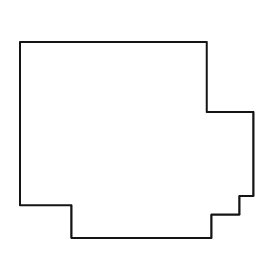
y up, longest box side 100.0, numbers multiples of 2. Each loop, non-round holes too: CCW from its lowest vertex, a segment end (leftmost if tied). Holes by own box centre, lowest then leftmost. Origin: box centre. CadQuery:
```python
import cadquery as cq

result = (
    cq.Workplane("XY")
    .moveTo(-28.0, -42.0)
    .lineTo(32.0, -42.0)
    .lineTo(32.0, -32.0)
    .lineTo(44.0, -32.0)
    .lineTo(44.0, -24.0)
    .lineTo(50.0, -24.0)
    .lineTo(50.0, 12.0)
    .lineTo(30.0, 12.0)
    .lineTo(30.0, 42.0)
    .lineTo(-50.0, 42.0)
    .lineTo(-50.0, -28.0)
    .lineTo(-28.0, -28.0)
    .close()
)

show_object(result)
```